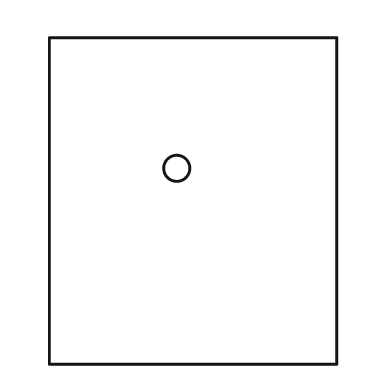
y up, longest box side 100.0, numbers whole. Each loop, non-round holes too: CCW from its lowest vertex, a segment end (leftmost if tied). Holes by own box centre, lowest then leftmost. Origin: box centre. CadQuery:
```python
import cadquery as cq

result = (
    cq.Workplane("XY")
    .moveTo(-44.0, -50.0)
    .lineTo(44.0, -50.0)
    .lineTo(44.0, 50.0)
    .lineTo(-44.0, 50.0)
    .close()
    .moveTo(-5.0, 10.0)
    .circle(4.0)
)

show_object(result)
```